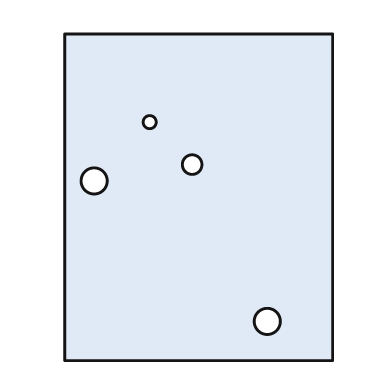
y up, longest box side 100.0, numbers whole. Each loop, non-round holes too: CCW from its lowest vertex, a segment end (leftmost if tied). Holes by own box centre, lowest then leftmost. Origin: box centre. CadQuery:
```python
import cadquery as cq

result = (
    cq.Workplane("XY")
    .moveTo(-41.0, -50.0)
    .lineTo(41.0, -50.0)
    .lineTo(41.0, 50.0)
    .lineTo(-41.0, 50.0)
    .close()
    .moveTo(21.0, -38.0)
    .circle(4.0)
    .moveTo(-32.0, 5.0)
    .circle(4.0)
    .moveTo(-2.0, 10.0)
    .circle(3.0)
    .moveTo(-15.0, 23.0)
    .circle(2.0)
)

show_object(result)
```